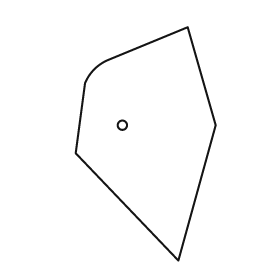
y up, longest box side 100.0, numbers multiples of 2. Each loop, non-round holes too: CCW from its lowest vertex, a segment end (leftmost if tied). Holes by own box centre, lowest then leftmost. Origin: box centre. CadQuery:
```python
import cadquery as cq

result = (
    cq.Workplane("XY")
    .moveTo(14.0, -50.0)
    .lineTo(30.0, 8.0)
    .lineTo(18.0, 50.0)
    .lineTo(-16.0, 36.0)
    .threePointArc((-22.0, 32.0), (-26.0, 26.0))
    .lineTo(-30.0, -4.0)
    .close()
    .moveTo(-10.0, 8.0)
    .circle(2.0)
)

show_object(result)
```